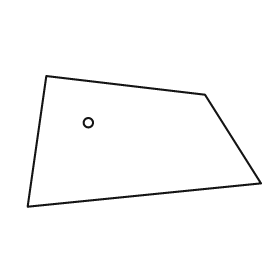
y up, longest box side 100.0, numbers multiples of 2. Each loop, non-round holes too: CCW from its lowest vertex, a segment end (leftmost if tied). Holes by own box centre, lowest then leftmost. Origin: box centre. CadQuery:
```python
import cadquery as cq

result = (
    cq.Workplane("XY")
    .moveTo(-50.0, -28.0)
    .lineTo(50.0, -18.0)
    .lineTo(26.0, 20.0)
    .lineTo(-42.0, 28.0)
    .close()
    .moveTo(-24.0, 8.0)
    .circle(2.0)
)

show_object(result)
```